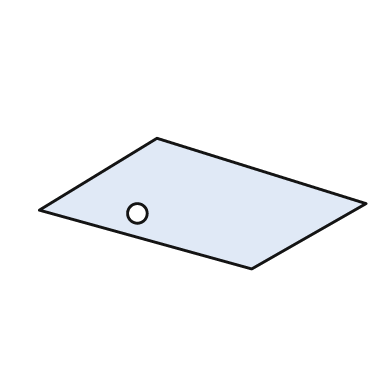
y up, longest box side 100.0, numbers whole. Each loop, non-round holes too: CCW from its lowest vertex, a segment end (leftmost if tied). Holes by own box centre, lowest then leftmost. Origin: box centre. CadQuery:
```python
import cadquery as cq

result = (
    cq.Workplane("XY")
    .moveTo(15.0, -20.0)
    .lineTo(50.0, 0.0)
    .lineTo(-14.0, 20.0)
    .lineTo(-50.0, -2.0)
    .close()
    .moveTo(-20.0, -3.0)
    .circle(3.0)
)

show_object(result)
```